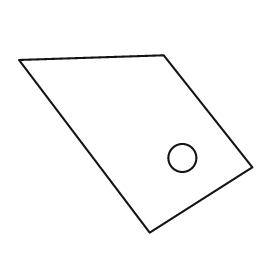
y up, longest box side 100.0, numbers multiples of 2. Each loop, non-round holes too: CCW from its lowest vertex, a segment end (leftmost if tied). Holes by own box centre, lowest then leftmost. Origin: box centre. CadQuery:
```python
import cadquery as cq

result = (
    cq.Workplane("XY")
    .moveTo(6.0, -38.0)
    .lineTo(50.0, -10.0)
    .lineTo(12.0, 38.0)
    .lineTo(-50.0, 36.0)
    .close()
    .moveTo(20.0, -6.0)
    .circle(6.0)
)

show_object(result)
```